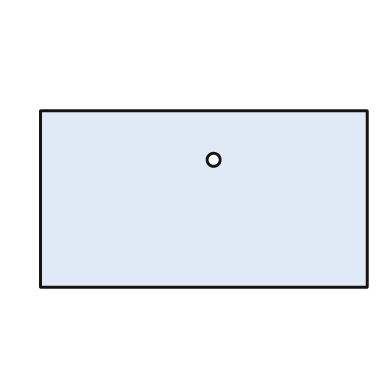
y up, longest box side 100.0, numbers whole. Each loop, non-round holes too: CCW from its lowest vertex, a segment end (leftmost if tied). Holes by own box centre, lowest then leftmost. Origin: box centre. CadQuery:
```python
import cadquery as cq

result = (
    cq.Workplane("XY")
    .moveTo(-50.0, -27.0)
    .lineTo(50.0, -27.0)
    .lineTo(50.0, 27.0)
    .lineTo(-50.0, 27.0)
    .close()
    .moveTo(3.0, 12.0)
    .circle(2.0)
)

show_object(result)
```